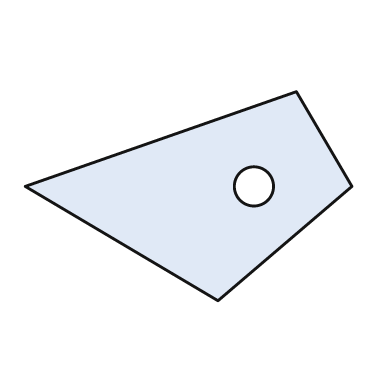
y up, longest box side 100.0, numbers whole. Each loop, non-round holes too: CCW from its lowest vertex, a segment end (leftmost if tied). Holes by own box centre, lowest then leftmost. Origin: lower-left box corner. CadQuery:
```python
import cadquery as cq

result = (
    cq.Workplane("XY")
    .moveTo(59.0, 0.0)
    .lineTo(100.0, 35.0)
    .lineTo(83.0, 64.0)
    .lineTo(0.0, 35.0)
    .close()
    .moveTo(70.0, 35.0)
    .circle(6.0)
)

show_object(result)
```